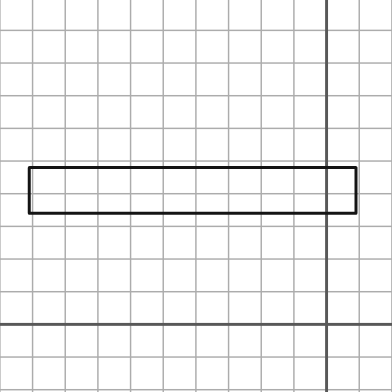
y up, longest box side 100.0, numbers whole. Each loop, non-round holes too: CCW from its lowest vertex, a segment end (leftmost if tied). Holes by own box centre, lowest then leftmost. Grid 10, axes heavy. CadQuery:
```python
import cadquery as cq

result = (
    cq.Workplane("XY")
    .moveTo(-91.0, 34.0)
    .lineTo(9.0, 34.0)
    .lineTo(9.0, 48.0)
    .lineTo(-91.0, 48.0)
    .close()
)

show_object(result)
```